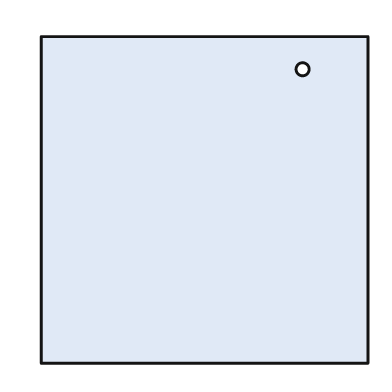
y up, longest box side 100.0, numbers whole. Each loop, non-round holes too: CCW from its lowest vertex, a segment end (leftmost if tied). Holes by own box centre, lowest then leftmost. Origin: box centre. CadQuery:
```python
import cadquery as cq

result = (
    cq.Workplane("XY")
    .moveTo(-50.0, -50.0)
    .lineTo(50.0, -50.0)
    .lineTo(50.0, 50.0)
    .lineTo(-50.0, 50.0)
    .close()
    .moveTo(30.0, 40.0)
    .circle(2.0)
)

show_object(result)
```